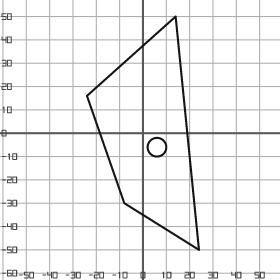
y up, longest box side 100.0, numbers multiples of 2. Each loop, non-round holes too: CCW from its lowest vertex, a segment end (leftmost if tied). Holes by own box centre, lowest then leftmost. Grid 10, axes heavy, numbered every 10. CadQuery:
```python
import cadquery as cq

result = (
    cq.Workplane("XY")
    .moveTo(24.0, -50.0)
    .lineTo(14.0, 50.0)
    .lineTo(-24.0, 16.0)
    .lineTo(-8.0, -30.0)
    .close()
    .moveTo(6.0, -6.0)
    .circle(4.0)
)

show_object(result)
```